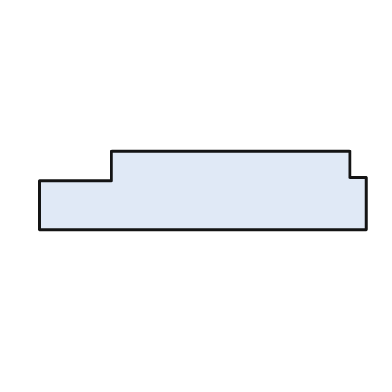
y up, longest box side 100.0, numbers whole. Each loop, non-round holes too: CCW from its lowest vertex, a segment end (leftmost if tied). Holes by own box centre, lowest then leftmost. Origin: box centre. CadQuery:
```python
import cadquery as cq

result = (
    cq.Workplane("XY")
    .moveTo(-50.0, -12.0)
    .lineTo(50.0, -12.0)
    .lineTo(50.0, 4.0)
    .lineTo(45.0, 4.0)
    .lineTo(45.0, 12.0)
    .lineTo(-28.0, 12.0)
    .lineTo(-28.0, 3.0)
    .lineTo(-50.0, 3.0)
    .close()
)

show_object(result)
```